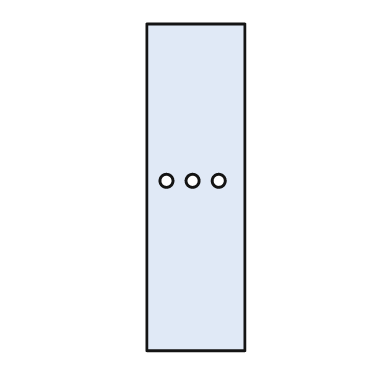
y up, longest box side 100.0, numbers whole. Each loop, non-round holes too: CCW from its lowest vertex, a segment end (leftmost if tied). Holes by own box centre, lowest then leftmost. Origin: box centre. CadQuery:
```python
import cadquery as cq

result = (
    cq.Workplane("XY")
    .moveTo(-15.0, -50.0)
    .lineTo(15.0, -50.0)
    .lineTo(15.0, 50.0)
    .lineTo(-15.0, 50.0)
    .close()
    .moveTo(-9.0, 2.0)
    .circle(2.0)
    .moveTo(-1.0, 2.0)
    .circle(2.0)
    .moveTo(7.0, 2.0)
    .circle(2.0)
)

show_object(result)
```